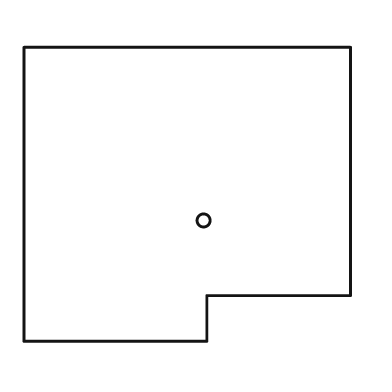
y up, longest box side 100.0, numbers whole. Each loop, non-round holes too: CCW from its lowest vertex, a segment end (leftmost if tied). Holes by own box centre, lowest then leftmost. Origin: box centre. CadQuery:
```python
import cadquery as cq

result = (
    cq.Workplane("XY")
    .moveTo(-50.0, -45.0)
    .lineTo(6.0, -45.0)
    .lineTo(6.0, -31.0)
    .lineTo(50.0, -31.0)
    .lineTo(50.0, 45.0)
    .lineTo(-50.0, 45.0)
    .close()
    .moveTo(5.0, -8.0)
    .circle(2.0)
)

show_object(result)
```